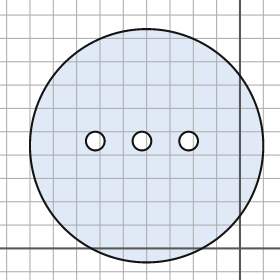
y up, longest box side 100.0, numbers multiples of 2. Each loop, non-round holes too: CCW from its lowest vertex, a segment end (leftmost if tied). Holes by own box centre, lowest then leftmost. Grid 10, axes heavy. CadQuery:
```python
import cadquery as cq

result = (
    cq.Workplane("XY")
    .moveTo(-40.0, 44.0)
    .circle(50.0)
    .moveTo(-62.0, 46.0)
    .circle(4.0)
    .moveTo(-42.0, 46.0)
    .circle(4.0)
    .moveTo(-22.0, 46.0)
    .circle(4.0)
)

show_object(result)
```